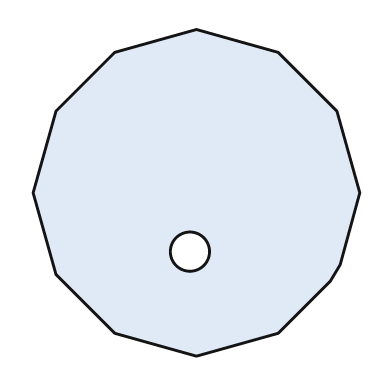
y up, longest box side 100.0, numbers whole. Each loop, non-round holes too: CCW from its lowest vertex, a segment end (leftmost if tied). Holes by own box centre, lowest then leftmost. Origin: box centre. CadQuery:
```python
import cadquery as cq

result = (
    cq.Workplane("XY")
    .moveTo(0.0, -50.0)
    .lineTo(25.0, -43.0)
    .lineTo(41.0, -27.0)
    .lineTo(44.0, -22.0)
    .lineTo(50.0, 0.0)
    .lineTo(43.0, 25.0)
    .lineTo(25.0, 43.0)
    .lineTo(0.0, 50.0)
    .lineTo(-25.0, 43.0)
    .lineTo(-43.0, 25.0)
    .lineTo(-50.0, 0.0)
    .lineTo(-43.0, -25.0)
    .lineTo(-25.0, -43.0)
    .close()
    .moveTo(-2.0, -18.0)
    .circle(6.0)
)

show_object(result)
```